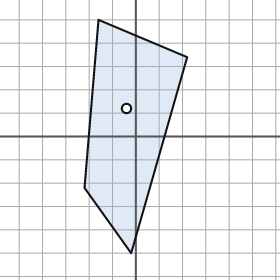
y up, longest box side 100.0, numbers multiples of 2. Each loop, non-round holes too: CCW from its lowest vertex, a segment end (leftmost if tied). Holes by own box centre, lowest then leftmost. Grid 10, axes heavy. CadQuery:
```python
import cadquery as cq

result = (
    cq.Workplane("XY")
    .moveTo(-2.0, -50.0)
    .lineTo(22.0, 34.0)
    .lineTo(-16.0, 50.0)
    .lineTo(-22.0, -22.0)
    .close()
    .moveTo(-4.0, 12.0)
    .circle(2.0)
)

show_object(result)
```